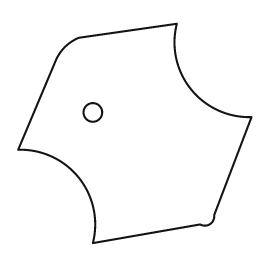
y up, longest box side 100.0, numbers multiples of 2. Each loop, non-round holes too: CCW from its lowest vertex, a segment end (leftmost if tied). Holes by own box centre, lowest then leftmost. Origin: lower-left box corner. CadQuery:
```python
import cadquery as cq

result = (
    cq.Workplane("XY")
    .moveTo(32.0, 0.0)
    .lineTo(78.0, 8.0)
    .threePointArc((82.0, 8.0), (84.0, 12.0))
    .lineTo(100.0, 54.0)
    .threePointArc((74.0, 66.0), (68.0, 94.0))
    .lineTo(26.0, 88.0)
    .threePointArc((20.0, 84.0), (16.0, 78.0))
    .lineTo(0.0, 40.0)
    .threePointArc((26.0, 28.0), (32.0, 0.0))
    .close()
    .moveTo(32.0, 56.0)
    .circle(4.0)
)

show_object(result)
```